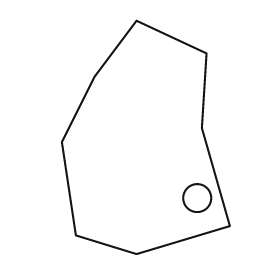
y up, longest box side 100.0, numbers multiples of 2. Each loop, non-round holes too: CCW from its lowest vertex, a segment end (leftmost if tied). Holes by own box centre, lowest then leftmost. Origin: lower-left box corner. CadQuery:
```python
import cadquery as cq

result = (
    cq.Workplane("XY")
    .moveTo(32.0, 0.0)
    .lineTo(72.0, 12.0)
    .lineTo(60.0, 54.0)
    .lineTo(62.0, 86.0)
    .lineTo(32.0, 100.0)
    .lineTo(14.0, 76.0)
    .lineTo(0.0, 48.0)
    .lineTo(6.0, 8.0)
    .close()
    .moveTo(58.0, 24.0)
    .circle(6.0)
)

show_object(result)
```